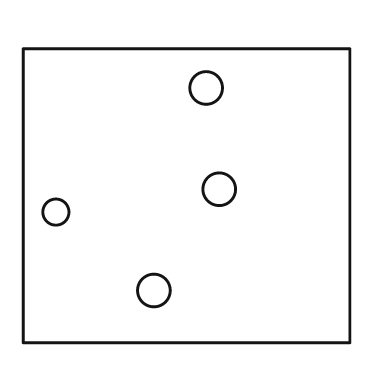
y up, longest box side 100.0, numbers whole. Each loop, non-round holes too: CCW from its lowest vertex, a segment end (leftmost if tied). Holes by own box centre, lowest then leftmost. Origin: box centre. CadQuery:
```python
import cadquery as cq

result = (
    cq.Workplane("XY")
    .moveTo(-50.0, -45.0)
    .lineTo(50.0, -45.0)
    .lineTo(50.0, 45.0)
    .lineTo(-50.0, 45.0)
    .close()
    .moveTo(-10.0, -29.0)
    .circle(5.0)
    .moveTo(-40.0, -5.0)
    .circle(4.0)
    .moveTo(10.0, 2.0)
    .circle(5.0)
    .moveTo(6.0, 33.0)
    .circle(5.0)
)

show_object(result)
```